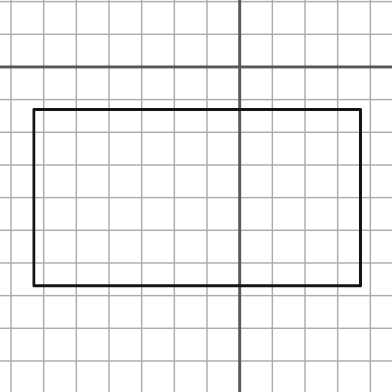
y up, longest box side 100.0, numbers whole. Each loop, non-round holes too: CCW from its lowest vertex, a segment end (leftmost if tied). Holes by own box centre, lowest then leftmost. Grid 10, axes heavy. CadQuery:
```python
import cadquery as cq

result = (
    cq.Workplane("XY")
    .moveTo(-63.0, -67.0)
    .lineTo(37.0, -67.0)
    .lineTo(37.0, -13.0)
    .lineTo(-63.0, -13.0)
    .close()
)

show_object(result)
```